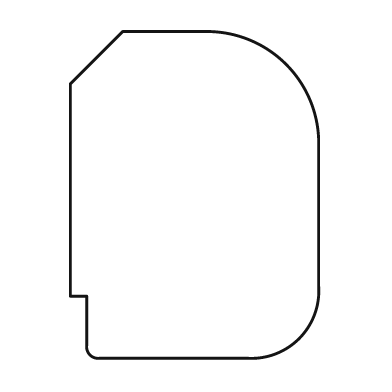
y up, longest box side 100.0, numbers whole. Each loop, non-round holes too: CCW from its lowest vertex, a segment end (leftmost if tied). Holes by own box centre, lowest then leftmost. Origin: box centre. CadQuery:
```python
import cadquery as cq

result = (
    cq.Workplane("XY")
    .moveTo(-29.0, -50.0)
    .lineTo(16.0, -50.0)
    .threePointArc((32.0, -44.0), (38.0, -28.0))
    .lineTo(38.0, 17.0)
    .threePointArc((28.0, 40.0), (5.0, 50.0))
    .lineTo(-22.0, 50.0)
    .lineTo(-38.0, 34.0)
    .lineTo(-38.0, -31.0)
    .lineTo(-33.0, -31.0)
    .lineTo(-33.0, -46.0)
    .threePointArc((-32.0, -49.0), (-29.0, -50.0))
    .close()
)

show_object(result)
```